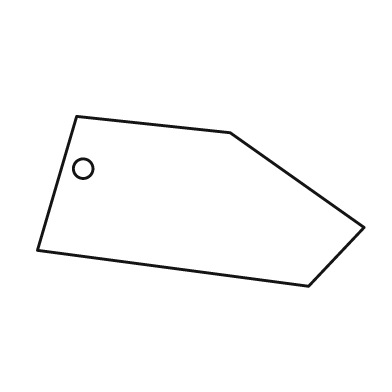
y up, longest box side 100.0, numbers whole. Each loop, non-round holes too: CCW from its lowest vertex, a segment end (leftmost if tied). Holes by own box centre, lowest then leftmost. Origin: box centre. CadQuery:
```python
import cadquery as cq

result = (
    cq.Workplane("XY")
    .moveTo(33.0, -26.0)
    .lineTo(50.0, -8.0)
    .lineTo(9.0, 21.0)
    .lineTo(-38.0, 26.0)
    .lineTo(-50.0, -15.0)
    .close()
    .moveTo(-36.0, 10.0)
    .circle(3.0)
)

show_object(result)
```